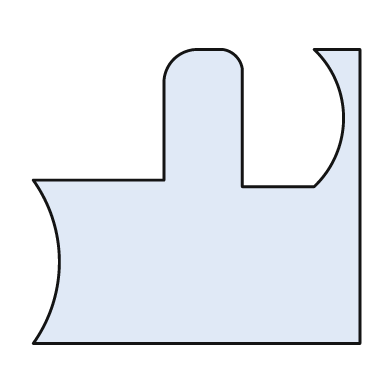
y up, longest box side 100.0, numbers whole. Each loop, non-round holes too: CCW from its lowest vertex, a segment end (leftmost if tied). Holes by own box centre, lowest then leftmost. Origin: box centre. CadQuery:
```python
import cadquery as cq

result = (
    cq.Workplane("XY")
    .moveTo(-50.0, -45.0)
    .lineTo(50.0, -45.0)
    .lineTo(50.0, 45.0)
    .lineTo(36.0, 45.0)
    .threePointArc((45.0, 24.0), (36.0, 3.0))
    .lineTo(14.0, 3.0)
    .lineTo(14.0, 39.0)
    .threePointArc((12.0, 43.0), (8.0, 45.0))
    .lineTo(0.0, 45.0)
    .threePointArc((-7.0, 42.0), (-10.0, 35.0))
    .lineTo(-10.0, 5.0)
    .lineTo(-50.0, 5.0)
    .threePointArc((-42.0, -20.0), (-50.0, -45.0))
    .close()
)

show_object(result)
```